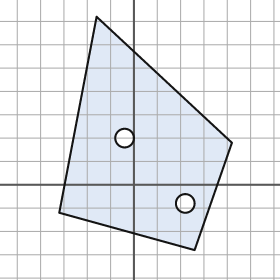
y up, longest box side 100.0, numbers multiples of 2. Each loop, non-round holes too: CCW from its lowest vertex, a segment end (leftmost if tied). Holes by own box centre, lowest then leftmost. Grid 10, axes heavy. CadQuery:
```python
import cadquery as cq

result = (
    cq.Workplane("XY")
    .moveTo(26.0, -28.0)
    .lineTo(42.0, 18.0)
    .lineTo(-16.0, 72.0)
    .lineTo(-32.0, -12.0)
    .close()
    .moveTo(22.0, -8.0)
    .circle(4.0)
    .moveTo(-4.0, 20.0)
    .circle(4.0)
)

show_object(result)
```